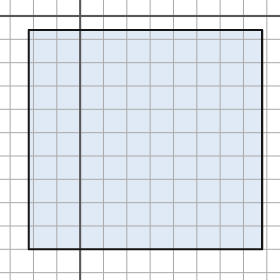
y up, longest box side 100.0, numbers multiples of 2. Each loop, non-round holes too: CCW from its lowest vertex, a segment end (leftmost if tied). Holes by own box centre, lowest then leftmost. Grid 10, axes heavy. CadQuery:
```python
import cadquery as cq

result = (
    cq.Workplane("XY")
    .moveTo(-22.0, -100.0)
    .lineTo(78.0, -100.0)
    .lineTo(78.0, -6.0)
    .lineTo(-22.0, -6.0)
    .close()
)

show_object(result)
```